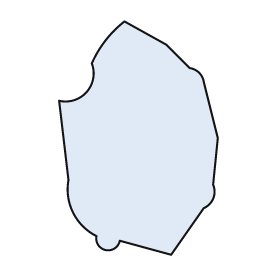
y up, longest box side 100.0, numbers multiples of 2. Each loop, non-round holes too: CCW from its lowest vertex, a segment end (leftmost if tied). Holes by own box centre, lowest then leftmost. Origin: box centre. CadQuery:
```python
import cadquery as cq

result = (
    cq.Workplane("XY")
    .moveTo(14.0, -50.0)
    .lineTo(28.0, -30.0)
    .threePointArc((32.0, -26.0), (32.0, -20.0))
    .lineTo(34.0, 0.0)
    .lineTo(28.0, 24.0)
    .threePointArc((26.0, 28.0), (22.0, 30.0))
    .lineTo(12.0, 40.0)
    .lineTo(-6.0, 50.0)
    .threePointArc((-14.0, 42.0), (-20.0, 32.0))
    .threePointArc((-22.0, 20.0), (-34.0, 16.0))
    .lineTo(-30.0, -18.0)
    .threePointArc((-28.0, -32.0), (-18.0, -42.0))
    .threePointArc((-14.0, -48.0), (-8.0, -44.0))
    .close()
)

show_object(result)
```